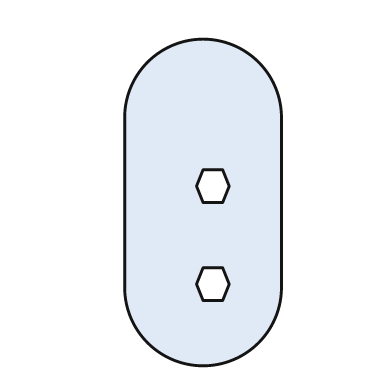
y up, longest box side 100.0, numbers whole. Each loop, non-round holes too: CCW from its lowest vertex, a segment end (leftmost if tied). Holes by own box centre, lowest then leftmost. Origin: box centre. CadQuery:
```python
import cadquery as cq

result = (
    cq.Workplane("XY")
    .moveTo(-24.0, -26.0)
    .threePointArc((0.0, -50.0), (24.0, -26.0))
    .lineTo(24.0, 26.0)
    .threePointArc((0.0, 50.0), (-24.0, 26.0))
    .close()
    .moveTo(0.0, -30.0)
    .lineTo(6.0, -30.0)
    .lineTo(8.0, -25.0)
    .lineTo(6.0, -20.0)
    .lineTo(0.0, -20.0)
    .lineTo(-2.0, -25.0)
    .close()
    .moveTo(0.0, 0.0)
    .lineTo(6.0, 0.0)
    .lineTo(8.0, 5.0)
    .lineTo(6.0, 10.0)
    .lineTo(0.0, 10.0)
    .lineTo(-2.0, 5.0)
    .close()
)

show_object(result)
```